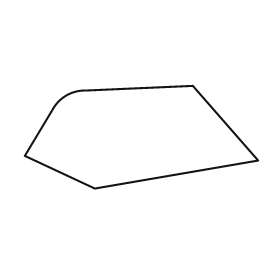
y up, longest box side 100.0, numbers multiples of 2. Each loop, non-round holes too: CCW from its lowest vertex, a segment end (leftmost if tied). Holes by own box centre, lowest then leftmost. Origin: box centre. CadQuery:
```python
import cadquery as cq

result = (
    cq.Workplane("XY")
    .moveTo(-20.0, -22.0)
    .lineTo(50.0, -10.0)
    .lineTo(22.0, 22.0)
    .lineTo(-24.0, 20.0)
    .threePointArc((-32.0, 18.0), (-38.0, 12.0))
    .lineTo(-50.0, -8.0)
    .close()
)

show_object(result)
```